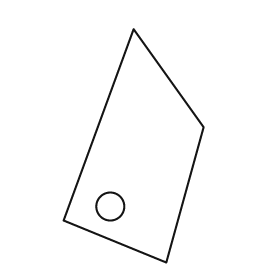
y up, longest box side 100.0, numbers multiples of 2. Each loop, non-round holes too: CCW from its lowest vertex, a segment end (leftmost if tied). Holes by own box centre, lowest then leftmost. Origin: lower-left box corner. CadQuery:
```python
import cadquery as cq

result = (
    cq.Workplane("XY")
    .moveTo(44.0, 0.0)
    .lineTo(60.0, 58.0)
    .lineTo(30.0, 100.0)
    .lineTo(0.0, 18.0)
    .close()
    .moveTo(20.0, 24.0)
    .circle(6.0)
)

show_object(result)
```